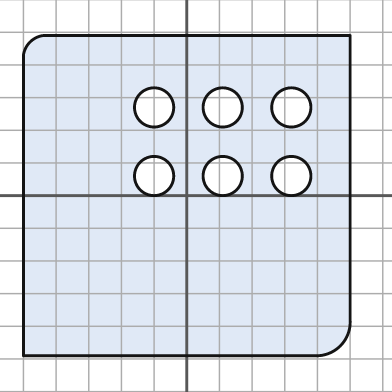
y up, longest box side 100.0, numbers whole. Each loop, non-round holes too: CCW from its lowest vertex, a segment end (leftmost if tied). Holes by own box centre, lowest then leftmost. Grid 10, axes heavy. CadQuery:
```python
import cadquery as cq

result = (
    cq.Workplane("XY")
    .moveTo(-50.0, -49.0)
    .lineTo(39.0, -49.0)
    .threePointArc((47.0, -46.0), (50.0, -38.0))
    .lineTo(50.0, 49.0)
    .lineTo(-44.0, 49.0)
    .threePointArc((-48.0, 47.0), (-50.0, 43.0))
    .close()
    .moveTo(-10.0, 6.0)
    .circle(6.0)
    .moveTo(11.0, 6.0)
    .circle(6.0)
    .moveTo(32.0, 6.0)
    .circle(6.0)
    .moveTo(-10.0, 27.0)
    .circle(6.0)
    .moveTo(11.0, 27.0)
    .circle(6.0)
    .moveTo(32.0, 27.0)
    .circle(6.0)
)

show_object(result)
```